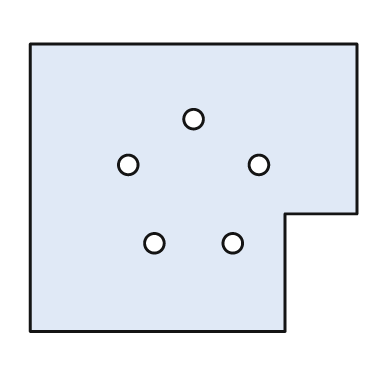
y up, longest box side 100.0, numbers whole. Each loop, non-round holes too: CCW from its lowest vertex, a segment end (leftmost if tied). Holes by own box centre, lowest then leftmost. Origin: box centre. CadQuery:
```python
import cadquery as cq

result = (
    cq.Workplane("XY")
    .moveTo(-50.0, -44.0)
    .lineTo(28.0, -44.0)
    .lineTo(28.0, -8.0)
    .lineTo(50.0, -8.0)
    .lineTo(50.0, 44.0)
    .lineTo(-50.0, 44.0)
    .close()
    .moveTo(-12.0, -17.0)
    .circle(3.0)
    .moveTo(12.0, -17.0)
    .circle(3.0)
    .moveTo(-20.0, 7.0)
    .circle(3.0)
    .moveTo(20.0, 7.0)
    .circle(3.0)
    .moveTo(0.0, 21.0)
    .circle(3.0)
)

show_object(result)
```